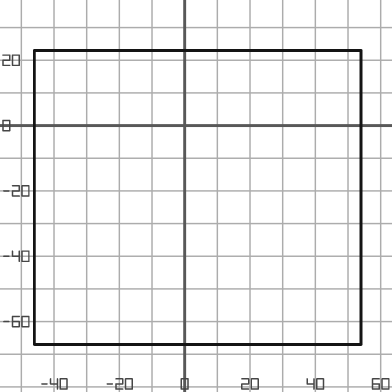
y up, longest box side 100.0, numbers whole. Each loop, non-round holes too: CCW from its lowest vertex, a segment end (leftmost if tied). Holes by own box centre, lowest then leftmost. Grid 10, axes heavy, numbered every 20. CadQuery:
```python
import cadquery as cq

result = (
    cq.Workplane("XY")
    .moveTo(-46.0, -67.0)
    .lineTo(54.0, -67.0)
    .lineTo(54.0, 23.0)
    .lineTo(-46.0, 23.0)
    .close()
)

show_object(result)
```